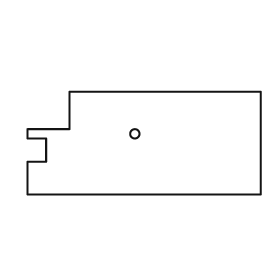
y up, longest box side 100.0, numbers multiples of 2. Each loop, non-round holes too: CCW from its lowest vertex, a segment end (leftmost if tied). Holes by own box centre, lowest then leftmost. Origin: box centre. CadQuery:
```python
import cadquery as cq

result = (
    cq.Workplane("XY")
    .moveTo(-50.0, -22.0)
    .lineTo(50.0, -22.0)
    .lineTo(50.0, 22.0)
    .lineTo(-32.0, 22.0)
    .lineTo(-32.0, 6.0)
    .lineTo(-50.0, 6.0)
    .lineTo(-50.0, 2.0)
    .lineTo(-42.0, 2.0)
    .lineTo(-42.0, -8.0)
    .lineTo(-50.0, -8.0)
    .close()
    .moveTo(-4.0, 4.0)
    .circle(2.0)
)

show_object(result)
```